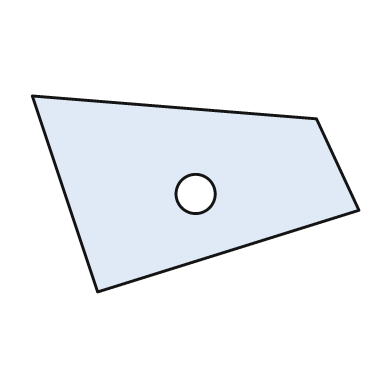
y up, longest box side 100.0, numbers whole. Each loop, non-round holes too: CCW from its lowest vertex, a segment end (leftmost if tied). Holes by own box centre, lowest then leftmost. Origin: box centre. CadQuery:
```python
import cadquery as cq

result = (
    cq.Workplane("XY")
    .moveTo(-30.0, -30.0)
    .lineTo(50.0, -5.0)
    .lineTo(37.0, 23.0)
    .lineTo(-50.0, 30.0)
    .close()
    .moveTo(0.0, 0.0)
    .circle(6.0)
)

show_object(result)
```